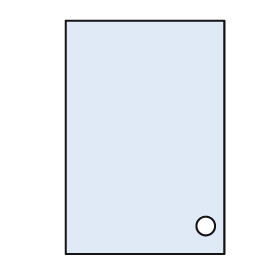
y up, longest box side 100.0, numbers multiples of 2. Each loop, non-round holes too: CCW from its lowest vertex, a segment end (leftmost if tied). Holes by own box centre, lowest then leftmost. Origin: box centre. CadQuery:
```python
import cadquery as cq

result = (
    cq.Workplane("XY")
    .moveTo(-34.0, -50.0)
    .lineTo(34.0, -50.0)
    .lineTo(34.0, 50.0)
    .lineTo(-34.0, 50.0)
    .close()
    .moveTo(26.0, -38.0)
    .circle(4.0)
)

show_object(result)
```